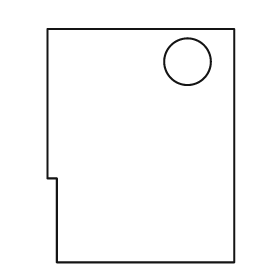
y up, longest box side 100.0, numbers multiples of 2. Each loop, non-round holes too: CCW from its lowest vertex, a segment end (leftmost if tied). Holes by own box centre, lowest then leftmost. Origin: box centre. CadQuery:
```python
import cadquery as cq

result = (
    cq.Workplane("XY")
    .moveTo(-36.0, -50.0)
    .lineTo(40.0, -50.0)
    .lineTo(40.0, 50.0)
    .lineTo(-40.0, 50.0)
    .lineTo(-40.0, -14.0)
    .lineTo(-36.0, -14.0)
    .close()
    .moveTo(20.0, 36.0)
    .circle(10.0)
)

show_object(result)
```